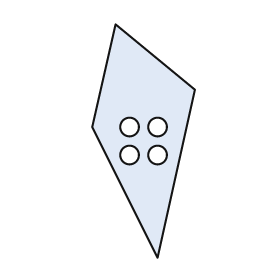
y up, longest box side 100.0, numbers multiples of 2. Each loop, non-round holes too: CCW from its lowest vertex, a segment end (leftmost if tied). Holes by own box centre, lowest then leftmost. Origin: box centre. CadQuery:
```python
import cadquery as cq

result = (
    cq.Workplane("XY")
    .moveTo(6.0, -50.0)
    .lineTo(22.0, 22.0)
    .lineTo(-12.0, 50.0)
    .lineTo(-22.0, 6.0)
    .close()
    .moveTo(-6.0, -6.0)
    .circle(4.0)
    .moveTo(6.0, -6.0)
    .circle(4.0)
    .moveTo(-6.0, 6.0)
    .circle(4.0)
    .moveTo(6.0, 6.0)
    .circle(4.0)
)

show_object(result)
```